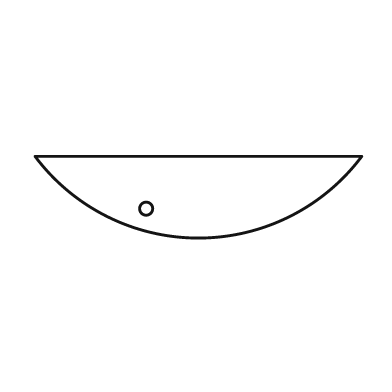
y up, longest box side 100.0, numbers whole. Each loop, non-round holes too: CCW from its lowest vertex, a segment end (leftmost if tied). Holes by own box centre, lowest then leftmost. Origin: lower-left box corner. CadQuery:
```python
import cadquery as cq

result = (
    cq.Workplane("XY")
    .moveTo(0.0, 25.0)
    .threePointArc((50.0, 0.0), (100.0, 25.0))
    .close()
    .moveTo(34.0, 9.0)
    .circle(2.0)
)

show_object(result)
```